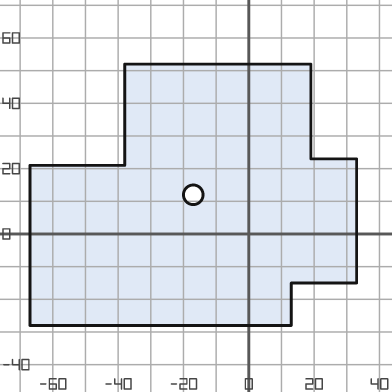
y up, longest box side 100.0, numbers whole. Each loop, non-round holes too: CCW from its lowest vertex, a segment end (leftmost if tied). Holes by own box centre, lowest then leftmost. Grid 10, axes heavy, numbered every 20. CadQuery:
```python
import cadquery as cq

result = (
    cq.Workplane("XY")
    .moveTo(-67.0, -28.0)
    .lineTo(13.0, -28.0)
    .lineTo(13.0, -15.0)
    .lineTo(33.0, -15.0)
    .lineTo(33.0, 23.0)
    .lineTo(19.0, 23.0)
    .lineTo(19.0, 52.0)
    .lineTo(-38.0, 52.0)
    .lineTo(-38.0, 21.0)
    .lineTo(-67.0, 21.0)
    .close()
    .moveTo(-17.0, 12.0)
    .circle(3.0)
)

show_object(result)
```